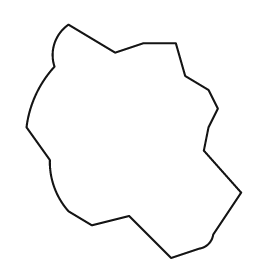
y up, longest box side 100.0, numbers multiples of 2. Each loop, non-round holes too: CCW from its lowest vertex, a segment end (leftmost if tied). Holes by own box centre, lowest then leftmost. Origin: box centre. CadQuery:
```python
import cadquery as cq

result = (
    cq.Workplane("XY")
    .moveTo(16.0, -50.0)
    .lineTo(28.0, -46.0)
    .threePointArc((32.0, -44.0), (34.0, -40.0))
    .lineTo(46.0, -22.0)
    .lineTo(30.0, -4.0)
    .lineTo(32.0, 6.0)
    .lineTo(36.0, 14.0)
    .lineTo(32.0, 22.0)
    .lineTo(22.0, 28.0)
    .lineTo(18.0, 42.0)
    .lineTo(4.0, 42.0)
    .lineTo(-8.0, 38.0)
    .lineTo(-28.0, 50.0)
    .threePointArc((-34.0, 42.0), (-34.0, 32.0))
    .threePointArc((-42.0, 20.0), (-46.0, 6.0))
    .lineTo(-36.0, -8.0)
    .threePointArc((-34.0, -20.0), (-28.0, -30.0))
    .lineTo(-18.0, -36.0)
    .lineTo(-2.0, -32.0)
    .close()
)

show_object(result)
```